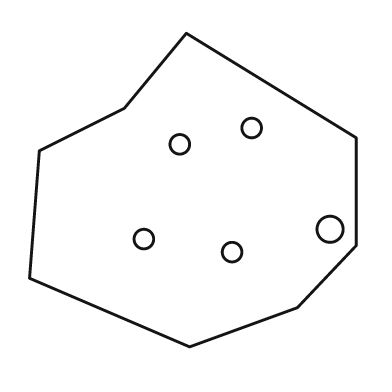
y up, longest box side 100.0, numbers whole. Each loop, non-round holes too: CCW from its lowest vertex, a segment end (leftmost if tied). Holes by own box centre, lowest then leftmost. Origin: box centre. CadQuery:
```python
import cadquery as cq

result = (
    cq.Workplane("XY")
    .moveTo(-1.0, -48.0)
    .lineTo(32.0, -36.0)
    .lineTo(50.0, -17.0)
    .lineTo(50.0, 16.0)
    .lineTo(-2.0, 48.0)
    .lineTo(-21.0, 25.0)
    .lineTo(-47.0, 12.0)
    .lineTo(-50.0, -27.0)
    .close()
    .moveTo(12.0, -19.0)
    .circle(3.0)
    .moveTo(-15.0, -15.0)
    .circle(3.0)
    .moveTo(42.0, -12.0)
    .circle(4.0)
    .moveTo(-4.0, 14.0)
    .circle(3.0)
    .moveTo(18.0, 19.0)
    .circle(3.0)
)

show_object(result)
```